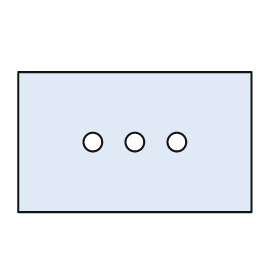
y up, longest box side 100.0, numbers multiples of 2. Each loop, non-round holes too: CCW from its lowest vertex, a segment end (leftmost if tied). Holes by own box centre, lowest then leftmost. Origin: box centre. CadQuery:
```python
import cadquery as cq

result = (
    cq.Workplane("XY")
    .moveTo(-50.0, -30.0)
    .lineTo(50.0, -30.0)
    .lineTo(50.0, 30.0)
    .lineTo(-50.0, 30.0)
    .close()
    .moveTo(-18.0, 0.0)
    .circle(4.0)
    .moveTo(0.0, 0.0)
    .circle(4.0)
    .moveTo(18.0, 0.0)
    .circle(4.0)
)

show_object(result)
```